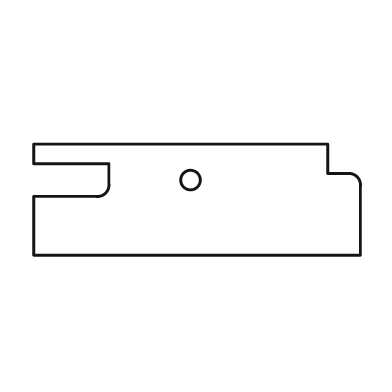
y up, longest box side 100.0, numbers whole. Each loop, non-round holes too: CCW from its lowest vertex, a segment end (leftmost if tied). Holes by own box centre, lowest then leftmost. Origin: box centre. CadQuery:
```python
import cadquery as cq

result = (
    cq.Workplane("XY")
    .moveTo(-50.0, -17.0)
    .lineTo(50.0, -17.0)
    .lineTo(50.0, 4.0)
    .threePointArc((49.0, 7.0), (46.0, 8.0))
    .lineTo(40.0, 8.0)
    .lineTo(40.0, 17.0)
    .lineTo(-50.0, 17.0)
    .lineTo(-50.0, 11.0)
    .lineTo(-27.0, 11.0)
    .lineTo(-27.0, 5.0)
    .threePointArc((-28.0, 2.0), (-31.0, 1.0))
    .lineTo(-50.0, 1.0)
    .close()
    .moveTo(-2.0, 6.0)
    .circle(3.0)
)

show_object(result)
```